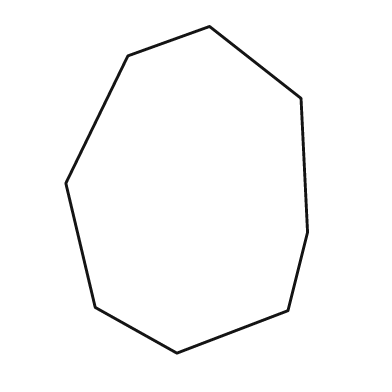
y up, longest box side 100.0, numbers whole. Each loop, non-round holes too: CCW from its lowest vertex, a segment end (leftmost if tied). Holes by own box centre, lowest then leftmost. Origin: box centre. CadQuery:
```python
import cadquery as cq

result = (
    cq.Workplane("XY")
    .moveTo(-3.0, -50.0)
    .lineTo(31.0, -37.0)
    .lineTo(37.0, -13.0)
    .lineTo(35.0, 28.0)
    .lineTo(7.0, 50.0)
    .lineTo(-18.0, 41.0)
    .lineTo(-37.0, 2.0)
    .lineTo(-28.0, -36.0)
    .close()
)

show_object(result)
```